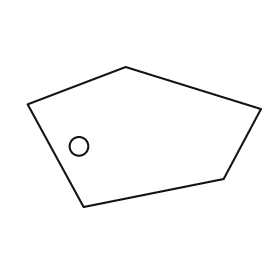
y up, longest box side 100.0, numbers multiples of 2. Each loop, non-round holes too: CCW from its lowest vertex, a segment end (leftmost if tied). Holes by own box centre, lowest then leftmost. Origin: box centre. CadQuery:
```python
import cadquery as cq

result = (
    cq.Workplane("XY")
    .moveTo(-26.0, -30.0)
    .lineTo(34.0, -18.0)
    .lineTo(50.0, 12.0)
    .lineTo(-8.0, 30.0)
    .lineTo(-50.0, 14.0)
    .close()
    .moveTo(-28.0, -4.0)
    .circle(4.0)
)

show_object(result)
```